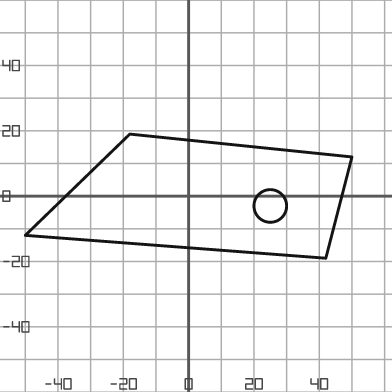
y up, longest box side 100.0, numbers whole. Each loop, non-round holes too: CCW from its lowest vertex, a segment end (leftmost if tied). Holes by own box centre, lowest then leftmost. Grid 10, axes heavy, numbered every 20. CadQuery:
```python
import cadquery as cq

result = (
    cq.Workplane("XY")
    .moveTo(42.0, -19.0)
    .lineTo(50.0, 12.0)
    .lineTo(-18.0, 19.0)
    .lineTo(-50.0, -12.0)
    .close()
    .moveTo(25.0, -3.0)
    .circle(5.0)
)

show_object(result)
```